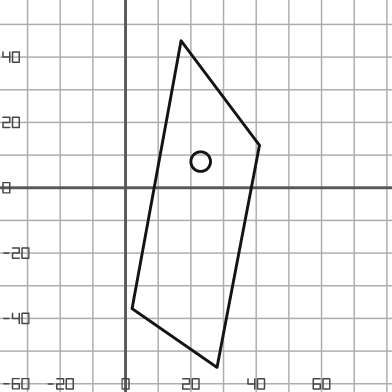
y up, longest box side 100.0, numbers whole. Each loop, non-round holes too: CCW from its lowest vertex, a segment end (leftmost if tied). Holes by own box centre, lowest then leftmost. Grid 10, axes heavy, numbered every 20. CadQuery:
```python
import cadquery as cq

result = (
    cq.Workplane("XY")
    .moveTo(28.0, -55.0)
    .lineTo(41.0, 13.0)
    .lineTo(17.0, 45.0)
    .lineTo(2.0, -37.0)
    .close()
    .moveTo(23.0, 8.0)
    .circle(3.0)
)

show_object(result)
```